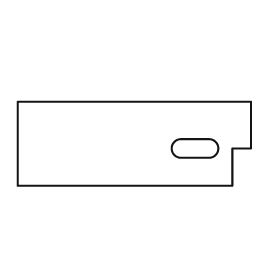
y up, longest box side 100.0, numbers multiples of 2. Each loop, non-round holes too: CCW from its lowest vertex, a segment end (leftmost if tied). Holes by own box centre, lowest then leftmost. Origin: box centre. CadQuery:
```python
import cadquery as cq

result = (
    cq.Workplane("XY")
    .moveTo(-50.0, -18.0)
    .lineTo(42.0, -18.0)
    .lineTo(42.0, -2.0)
    .lineTo(50.0, -2.0)
    .lineTo(50.0, 18.0)
    .lineTo(-50.0, 18.0)
    .close()
    .moveTo(20.0, -6.0)
    .lineTo(32.0, -6.0)
    .threePointArc((36.0, -2.0), (32.0, 2.0))
    .lineTo(20.0, 2.0)
    .threePointArc((16.0, -2.0), (20.0, -6.0))
    .close()
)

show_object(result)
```